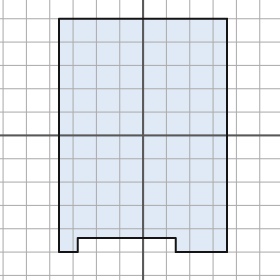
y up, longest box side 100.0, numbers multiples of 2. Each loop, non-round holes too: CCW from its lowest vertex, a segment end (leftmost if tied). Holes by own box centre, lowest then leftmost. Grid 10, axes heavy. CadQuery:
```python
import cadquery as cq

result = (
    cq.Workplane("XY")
    .moveTo(-36.0, -50.0)
    .lineTo(-28.0, -50.0)
    .lineTo(-28.0, -44.0)
    .lineTo(14.0, -44.0)
    .lineTo(14.0, -50.0)
    .lineTo(36.0, -50.0)
    .lineTo(36.0, 50.0)
    .lineTo(-36.0, 50.0)
    .close()
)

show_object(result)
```